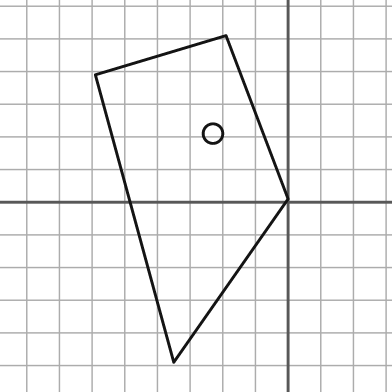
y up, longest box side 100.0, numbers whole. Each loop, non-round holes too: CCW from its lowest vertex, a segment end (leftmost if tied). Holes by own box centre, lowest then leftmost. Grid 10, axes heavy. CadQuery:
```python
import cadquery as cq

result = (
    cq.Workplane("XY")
    .moveTo(-35.0, -49.0)
    .lineTo(0.0, 1.0)
    .lineTo(-19.0, 51.0)
    .lineTo(-59.0, 39.0)
    .close()
    .moveTo(-23.0, 21.0)
    .circle(3.0)
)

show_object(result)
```